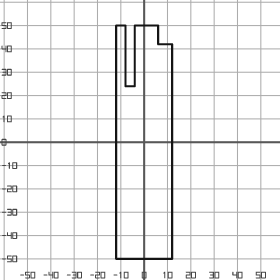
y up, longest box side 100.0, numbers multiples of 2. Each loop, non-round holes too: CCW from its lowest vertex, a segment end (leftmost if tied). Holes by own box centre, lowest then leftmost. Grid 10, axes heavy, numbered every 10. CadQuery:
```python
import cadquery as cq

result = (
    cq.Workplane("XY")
    .moveTo(-12.0, -50.0)
    .lineTo(12.0, -50.0)
    .lineTo(12.0, 42.0)
    .lineTo(6.0, 42.0)
    .lineTo(6.0, 50.0)
    .lineTo(-4.0, 50.0)
    .lineTo(-4.0, 24.0)
    .lineTo(-8.0, 24.0)
    .lineTo(-8.0, 50.0)
    .lineTo(-12.0, 50.0)
    .close()
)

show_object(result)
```